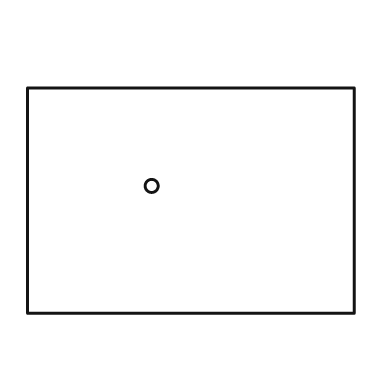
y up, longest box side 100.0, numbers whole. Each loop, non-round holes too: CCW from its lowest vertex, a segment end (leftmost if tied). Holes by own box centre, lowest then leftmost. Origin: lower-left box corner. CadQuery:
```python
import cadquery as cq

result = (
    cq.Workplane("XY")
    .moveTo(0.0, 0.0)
    .lineTo(100.0, 0.0)
    .lineTo(100.0, 69.0)
    .lineTo(0.0, 69.0)
    .close()
    .moveTo(38.0, 39.0)
    .circle(2.0)
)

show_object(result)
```